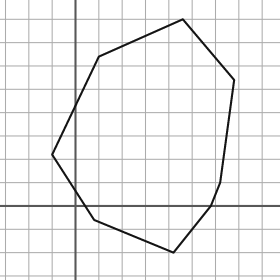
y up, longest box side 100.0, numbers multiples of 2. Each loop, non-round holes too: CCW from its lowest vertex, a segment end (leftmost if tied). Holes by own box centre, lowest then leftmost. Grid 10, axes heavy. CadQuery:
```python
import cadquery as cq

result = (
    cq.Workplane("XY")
    .moveTo(42.0, -20.0)
    .lineTo(58.0, 0.0)
    .lineTo(62.0, 10.0)
    .lineTo(68.0, 54.0)
    .lineTo(46.0, 80.0)
    .lineTo(10.0, 64.0)
    .lineTo(-10.0, 22.0)
    .lineTo(8.0, -6.0)
    .close()
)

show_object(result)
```